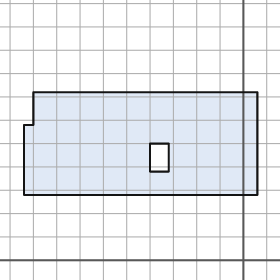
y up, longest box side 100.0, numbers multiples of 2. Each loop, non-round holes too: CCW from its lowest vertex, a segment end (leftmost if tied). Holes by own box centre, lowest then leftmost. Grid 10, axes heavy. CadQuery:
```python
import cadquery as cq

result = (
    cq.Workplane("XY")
    .moveTo(-94.0, 28.0)
    .lineTo(6.0, 28.0)
    .lineTo(6.0, 72.0)
    .lineTo(-90.0, 72.0)
    .lineTo(-90.0, 58.0)
    .lineTo(-94.0, 58.0)
    .close()
    .moveTo(-40.0, 38.0)
    .lineTo(-32.0, 38.0)
    .lineTo(-32.0, 50.0)
    .lineTo(-40.0, 50.0)
    .close()
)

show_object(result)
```